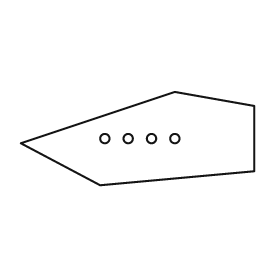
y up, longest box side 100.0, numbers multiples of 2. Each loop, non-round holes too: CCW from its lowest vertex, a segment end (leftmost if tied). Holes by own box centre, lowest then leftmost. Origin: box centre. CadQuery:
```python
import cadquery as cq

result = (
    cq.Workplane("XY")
    .moveTo(-16.0, -20.0)
    .lineTo(50.0, -14.0)
    .lineTo(50.0, 14.0)
    .lineTo(16.0, 20.0)
    .lineTo(-50.0, -2.0)
    .close()
    .moveTo(-14.0, 0.0)
    .circle(2.0)
    .moveTo(-4.0, 0.0)
    .circle(2.0)
    .moveTo(6.0, 0.0)
    .circle(2.0)
    .moveTo(16.0, 0.0)
    .circle(2.0)
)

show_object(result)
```